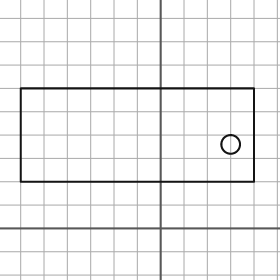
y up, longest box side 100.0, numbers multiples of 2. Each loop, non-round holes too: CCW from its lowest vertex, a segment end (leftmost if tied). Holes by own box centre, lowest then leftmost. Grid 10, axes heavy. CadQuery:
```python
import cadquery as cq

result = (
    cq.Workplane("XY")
    .moveTo(-60.0, 20.0)
    .lineTo(40.0, 20.0)
    .lineTo(40.0, 60.0)
    .lineTo(-60.0, 60.0)
    .close()
    .moveTo(30.0, 36.0)
    .circle(4.0)
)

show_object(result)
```